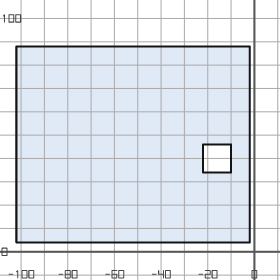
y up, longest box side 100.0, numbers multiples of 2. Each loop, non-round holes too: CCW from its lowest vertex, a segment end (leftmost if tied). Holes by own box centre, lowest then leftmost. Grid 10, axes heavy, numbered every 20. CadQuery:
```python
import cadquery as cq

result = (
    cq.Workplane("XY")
    .moveTo(-102.0, 4.0)
    .lineTo(-2.0, 4.0)
    .lineTo(-2.0, 88.0)
    .lineTo(-102.0, 88.0)
    .close()
    .moveTo(-22.0, 34.0)
    .lineTo(-10.0, 34.0)
    .lineTo(-10.0, 46.0)
    .lineTo(-22.0, 46.0)
    .close()
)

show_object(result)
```